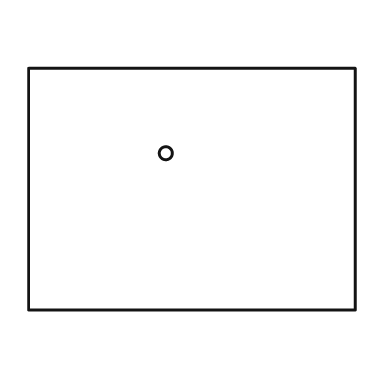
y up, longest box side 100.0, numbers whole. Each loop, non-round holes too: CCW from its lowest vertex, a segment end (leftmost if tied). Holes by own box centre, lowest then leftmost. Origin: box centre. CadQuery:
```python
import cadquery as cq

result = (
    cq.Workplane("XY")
    .moveTo(-50.0, -37.0)
    .lineTo(50.0, -37.0)
    .lineTo(50.0, 37.0)
    .lineTo(-50.0, 37.0)
    .close()
    .moveTo(-8.0, 11.0)
    .circle(2.0)
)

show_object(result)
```